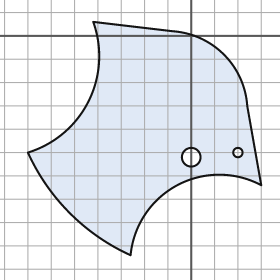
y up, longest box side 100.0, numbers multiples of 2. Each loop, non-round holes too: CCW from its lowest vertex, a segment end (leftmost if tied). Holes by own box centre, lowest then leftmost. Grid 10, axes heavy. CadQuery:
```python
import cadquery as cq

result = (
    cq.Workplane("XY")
    .moveTo(-26.0, -94.0)
    .threePointArc((-6.0, -64.0), (30.0, -64.0))
    .lineTo(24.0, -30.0)
    .threePointArc((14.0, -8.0), (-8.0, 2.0))
    .lineTo(-42.0, 6.0)
    .threePointArc((-44.0, -28.0), (-70.0, -50.0))
    .threePointArc((-52.0, -76.0), (-26.0, -94.0))
    .close()
    .moveTo(0.0, -52.0)
    .circle(4.0)
    .moveTo(20.0, -50.0)
    .circle(2.0)
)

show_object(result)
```